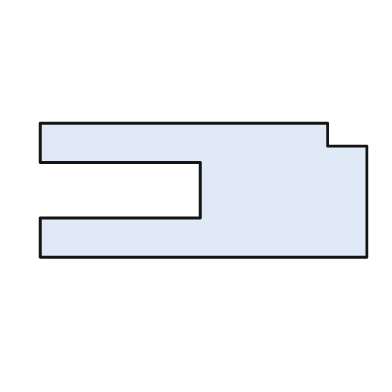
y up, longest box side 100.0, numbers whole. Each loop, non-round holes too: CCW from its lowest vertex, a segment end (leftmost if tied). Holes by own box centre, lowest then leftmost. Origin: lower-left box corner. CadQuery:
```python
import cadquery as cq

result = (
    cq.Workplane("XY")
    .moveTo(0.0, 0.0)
    .lineTo(100.0, 0.0)
    .lineTo(100.0, 34.0)
    .lineTo(88.0, 34.0)
    .lineTo(88.0, 41.0)
    .lineTo(0.0, 41.0)
    .lineTo(0.0, 29.0)
    .lineTo(49.0, 29.0)
    .lineTo(49.0, 12.0)
    .lineTo(0.0, 12.0)
    .close()
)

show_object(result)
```